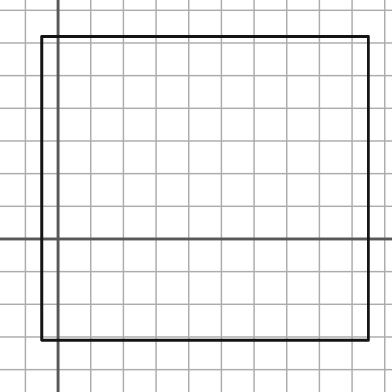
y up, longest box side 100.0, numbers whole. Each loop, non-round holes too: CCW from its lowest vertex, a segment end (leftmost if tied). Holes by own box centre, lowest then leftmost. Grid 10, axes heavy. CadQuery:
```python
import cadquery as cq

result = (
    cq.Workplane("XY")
    .moveTo(-5.0, -31.0)
    .lineTo(95.0, -31.0)
    .lineTo(95.0, 62.0)
    .lineTo(-5.0, 62.0)
    .close()
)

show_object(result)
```